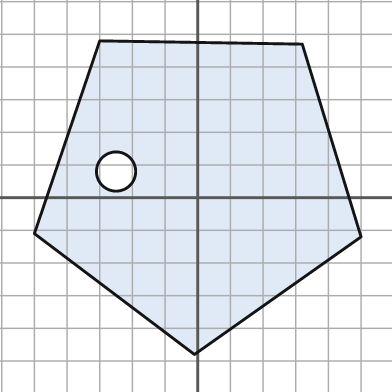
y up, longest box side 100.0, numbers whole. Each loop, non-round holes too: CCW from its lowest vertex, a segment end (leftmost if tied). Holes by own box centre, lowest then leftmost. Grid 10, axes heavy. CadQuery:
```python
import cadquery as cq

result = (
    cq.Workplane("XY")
    .moveTo(-1.0, -48.0)
    .lineTo(50.0, -12.0)
    .lineTo(32.0, 47.0)
    .lineTo(-30.0, 48.0)
    .lineTo(-50.0, -11.0)
    .close()
    .moveTo(-25.0, 8.0)
    .circle(6.0)
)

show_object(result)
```